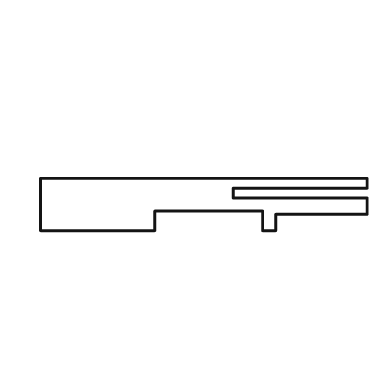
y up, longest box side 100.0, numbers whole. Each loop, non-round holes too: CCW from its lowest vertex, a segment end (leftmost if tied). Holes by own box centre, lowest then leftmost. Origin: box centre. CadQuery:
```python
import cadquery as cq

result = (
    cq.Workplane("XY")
    .moveTo(-50.0, -8.0)
    .lineTo(-15.0, -8.0)
    .lineTo(-15.0, -2.0)
    .lineTo(18.0, -2.0)
    .lineTo(18.0, -8.0)
    .lineTo(22.0, -8.0)
    .lineTo(22.0, -3.0)
    .lineTo(50.0, -3.0)
    .lineTo(50.0, 2.0)
    .lineTo(9.0, 2.0)
    .lineTo(9.0, 5.0)
    .lineTo(50.0, 5.0)
    .lineTo(50.0, 8.0)
    .lineTo(-50.0, 8.0)
    .close()
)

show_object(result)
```